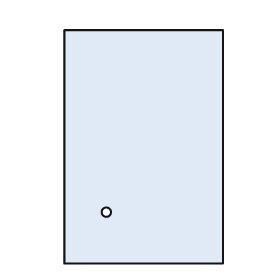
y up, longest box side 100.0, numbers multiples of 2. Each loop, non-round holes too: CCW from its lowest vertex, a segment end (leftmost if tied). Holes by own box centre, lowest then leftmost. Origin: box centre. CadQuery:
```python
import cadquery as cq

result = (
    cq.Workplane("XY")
    .moveTo(-34.0, -50.0)
    .lineTo(34.0, -50.0)
    .lineTo(34.0, 50.0)
    .lineTo(-34.0, 50.0)
    .close()
    .moveTo(-16.0, -28.0)
    .circle(2.0)
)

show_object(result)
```